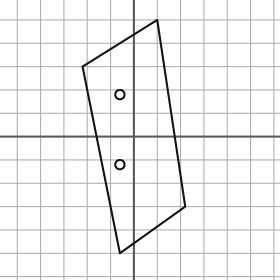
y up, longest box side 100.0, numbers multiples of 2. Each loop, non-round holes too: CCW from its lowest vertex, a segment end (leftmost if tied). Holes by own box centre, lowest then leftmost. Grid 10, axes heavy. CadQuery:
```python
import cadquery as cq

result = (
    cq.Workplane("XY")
    .moveTo(-6.0, -50.0)
    .lineTo(22.0, -30.0)
    .lineTo(10.0, 50.0)
    .lineTo(-22.0, 30.0)
    .close()
    .moveTo(-6.0, -12.0)
    .circle(2.0)
    .moveTo(-6.0, 18.0)
    .circle(2.0)
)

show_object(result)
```